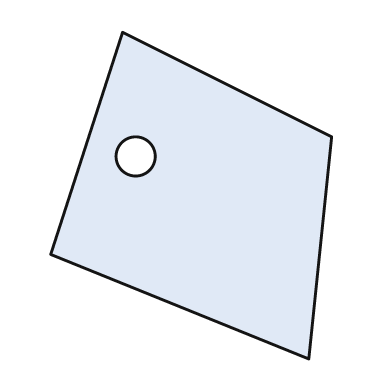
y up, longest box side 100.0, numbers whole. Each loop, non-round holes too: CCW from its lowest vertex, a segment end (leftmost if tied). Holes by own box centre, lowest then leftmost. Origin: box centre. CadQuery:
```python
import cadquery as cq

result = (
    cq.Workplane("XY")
    .moveTo(36.0, -50.0)
    .lineTo(43.0, 18.0)
    .lineTo(-21.0, 50.0)
    .lineTo(-43.0, -18.0)
    .close()
    .moveTo(-17.0, 12.0)
    .circle(6.0)
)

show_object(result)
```